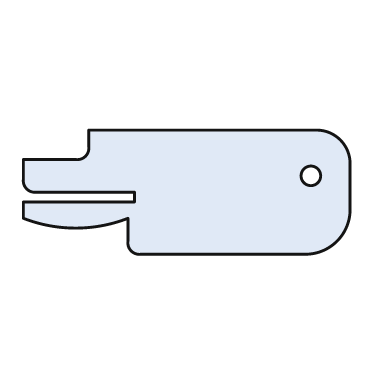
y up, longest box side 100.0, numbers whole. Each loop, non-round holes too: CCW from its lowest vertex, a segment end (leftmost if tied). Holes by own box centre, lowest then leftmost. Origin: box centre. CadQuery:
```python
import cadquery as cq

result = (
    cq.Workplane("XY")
    .moveTo(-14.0, -19.0)
    .lineTo(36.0, -19.0)
    .threePointArc((46.0, -15.0), (50.0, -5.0))
    .lineTo(50.0, 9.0)
    .threePointArc((47.0, 16.0), (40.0, 19.0))
    .lineTo(-30.0, 19.0)
    .lineTo(-30.0, 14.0)
    .threePointArc((-31.0, 11.0), (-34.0, 10.0))
    .lineTo(-50.0, 10.0)
    .lineTo(-50.0, 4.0)
    .threePointArc((-49.0, 1.0), (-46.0, 0.0))
    .lineTo(-16.0, 0.0)
    .lineTo(-16.0, -3.0)
    .lineTo(-50.0, -3.0)
    .lineTo(-50.0, -8.0)
    .threePointArc((-34.0, -11.0), (-18.0, -8.0))
    .lineTo(-18.0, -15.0)
    .threePointArc((-17.0, -18.0), (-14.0, -19.0))
    .close()
    .moveTo(38.0, 5.0)
    .circle(3.0)
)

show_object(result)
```